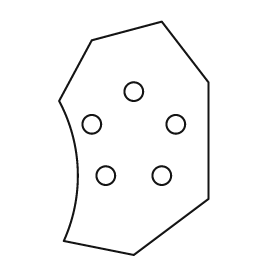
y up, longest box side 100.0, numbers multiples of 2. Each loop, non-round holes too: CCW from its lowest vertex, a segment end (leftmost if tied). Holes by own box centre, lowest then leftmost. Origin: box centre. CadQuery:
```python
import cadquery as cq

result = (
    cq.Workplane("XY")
    .moveTo(0.0, -50.0)
    .lineTo(32.0, -26.0)
    .lineTo(32.0, 24.0)
    .lineTo(12.0, 50.0)
    .lineTo(-18.0, 42.0)
    .lineTo(-32.0, 16.0)
    .threePointArc((-24.0, -14.0), (-30.0, -44.0))
    .close()
    .moveTo(-12.0, -16.0)
    .circle(4.0)
    .moveTo(12.0, -16.0)
    .circle(4.0)
    .moveTo(-18.0, 6.0)
    .circle(4.0)
    .moveTo(18.0, 6.0)
    .circle(4.0)
    .moveTo(0.0, 20.0)
    .circle(4.0)
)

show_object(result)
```